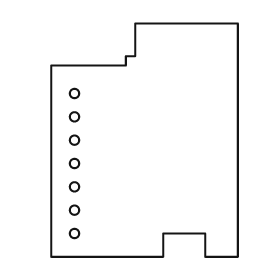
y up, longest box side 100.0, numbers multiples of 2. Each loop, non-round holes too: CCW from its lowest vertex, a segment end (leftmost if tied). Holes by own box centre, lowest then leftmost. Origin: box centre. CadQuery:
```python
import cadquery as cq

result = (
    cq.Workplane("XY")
    .moveTo(-40.0, -50.0)
    .lineTo(8.0, -50.0)
    .lineTo(8.0, -40.0)
    .lineTo(26.0, -40.0)
    .lineTo(26.0, -50.0)
    .lineTo(40.0, -50.0)
    .lineTo(40.0, 50.0)
    .lineTo(-4.0, 50.0)
    .lineTo(-4.0, 36.0)
    .lineTo(-8.0, 36.0)
    .lineTo(-8.0, 32.0)
    .lineTo(-40.0, 32.0)
    .close()
    .moveTo(-30.0, -40.0)
    .circle(2.0)
    .moveTo(-30.0, -30.0)
    .circle(2.0)
    .moveTo(-30.0, -20.0)
    .circle(2.0)
    .moveTo(-30.0, -10.0)
    .circle(2.0)
    .moveTo(-30.0, 0.0)
    .circle(2.0)
    .moveTo(-30.0, 10.0)
    .circle(2.0)
    .moveTo(-30.0, 20.0)
    .circle(2.0)
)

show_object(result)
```